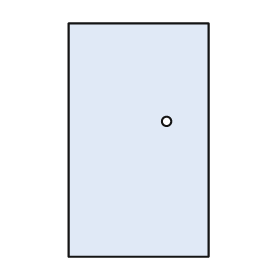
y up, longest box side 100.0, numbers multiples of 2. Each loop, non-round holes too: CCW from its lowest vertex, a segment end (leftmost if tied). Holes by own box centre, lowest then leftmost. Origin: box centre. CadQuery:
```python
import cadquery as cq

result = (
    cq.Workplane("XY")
    .moveTo(-30.0, -50.0)
    .lineTo(30.0, -50.0)
    .lineTo(30.0, 50.0)
    .lineTo(-30.0, 50.0)
    .close()
    .moveTo(12.0, 8.0)
    .circle(2.0)
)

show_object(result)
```